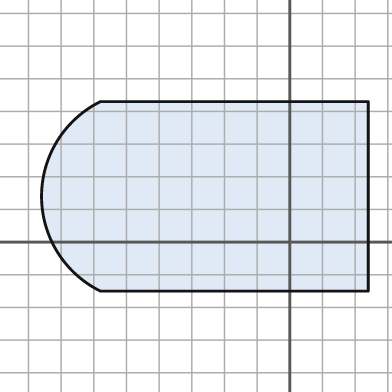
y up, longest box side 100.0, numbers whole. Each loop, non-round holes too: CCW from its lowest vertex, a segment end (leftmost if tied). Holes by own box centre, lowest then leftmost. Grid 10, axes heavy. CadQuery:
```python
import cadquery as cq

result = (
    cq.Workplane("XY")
    .moveTo(-58.0, -15.0)
    .lineTo(24.0, -15.0)
    .lineTo(24.0, 43.0)
    .lineTo(-58.0, 43.0)
    .threePointArc((-76.0, 14.0), (-58.0, -15.0))
    .close()
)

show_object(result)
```